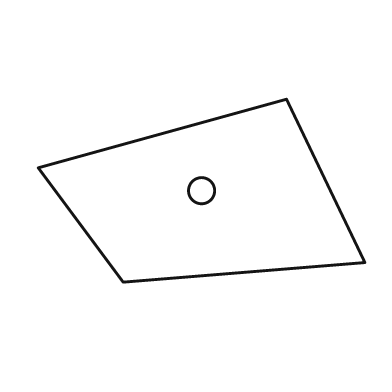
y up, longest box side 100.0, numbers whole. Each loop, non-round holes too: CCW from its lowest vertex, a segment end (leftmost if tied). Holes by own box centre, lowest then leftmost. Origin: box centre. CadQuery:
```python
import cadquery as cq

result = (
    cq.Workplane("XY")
    .moveTo(-24.0, -28.0)
    .lineTo(50.0, -22.0)
    .lineTo(26.0, 28.0)
    .lineTo(-50.0, 7.0)
    .close()
    .moveTo(0.0, 0.0)
    .circle(4.0)
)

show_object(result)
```